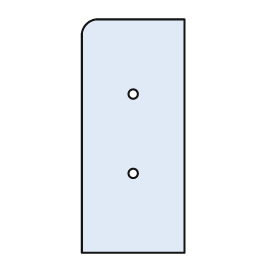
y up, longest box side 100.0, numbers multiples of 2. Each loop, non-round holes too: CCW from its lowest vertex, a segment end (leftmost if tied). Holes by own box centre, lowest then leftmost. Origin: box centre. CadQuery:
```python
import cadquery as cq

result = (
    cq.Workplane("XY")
    .moveTo(-22.0, -50.0)
    .lineTo(22.0, -50.0)
    .lineTo(22.0, 50.0)
    .lineTo(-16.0, 50.0)
    .threePointArc((-20.0, 48.0), (-22.0, 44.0))
    .close()
    .moveTo(0.0, -16.0)
    .circle(2.0)
    .moveTo(0.0, 18.0)
    .circle(2.0)
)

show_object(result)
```